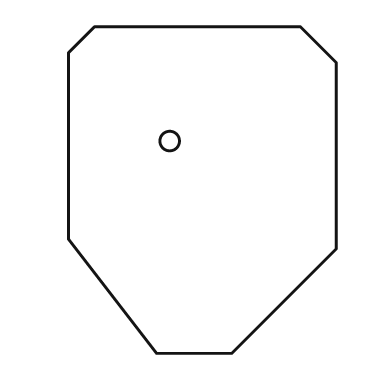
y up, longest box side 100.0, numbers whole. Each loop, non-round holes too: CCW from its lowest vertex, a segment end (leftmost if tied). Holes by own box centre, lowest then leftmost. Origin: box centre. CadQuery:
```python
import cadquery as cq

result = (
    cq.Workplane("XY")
    .moveTo(-14.0, -50.0)
    .lineTo(9.0, -50.0)
    .lineTo(41.0, -18.0)
    .lineTo(41.0, 39.0)
    .lineTo(30.0, 50.0)
    .lineTo(-33.0, 50.0)
    .lineTo(-41.0, 42.0)
    .lineTo(-41.0, -15.0)
    .close()
    .moveTo(-10.0, 15.0)
    .circle(3.0)
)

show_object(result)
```